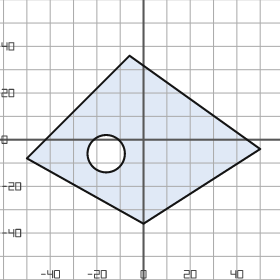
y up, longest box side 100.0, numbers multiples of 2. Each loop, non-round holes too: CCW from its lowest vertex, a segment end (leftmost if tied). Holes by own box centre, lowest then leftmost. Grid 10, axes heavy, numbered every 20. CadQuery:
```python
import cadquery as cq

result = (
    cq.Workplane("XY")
    .moveTo(0.0, -36.0)
    .lineTo(50.0, -4.0)
    .lineTo(-6.0, 36.0)
    .lineTo(-50.0, -8.0)
    .close()
    .moveTo(-16.0, -6.0)
    .circle(8.0)
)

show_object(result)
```